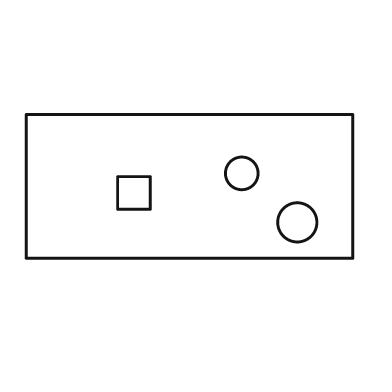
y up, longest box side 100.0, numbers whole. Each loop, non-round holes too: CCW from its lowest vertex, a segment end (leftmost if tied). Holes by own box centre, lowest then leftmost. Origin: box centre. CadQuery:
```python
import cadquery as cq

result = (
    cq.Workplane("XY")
    .moveTo(-50.0, -22.0)
    .lineTo(50.0, -22.0)
    .lineTo(50.0, 22.0)
    .lineTo(-50.0, 22.0)
    .close()
    .moveTo(33.0, -11.0)
    .circle(6.0)
    .moveTo(-22.0, -7.0)
    .lineTo(-12.0, -7.0)
    .lineTo(-12.0, 3.0)
    .lineTo(-22.0, 3.0)
    .close()
    .moveTo(16.0, 4.0)
    .circle(5.0)
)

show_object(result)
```